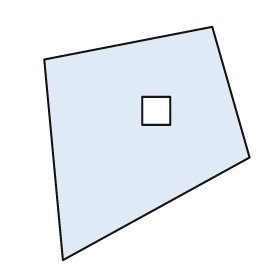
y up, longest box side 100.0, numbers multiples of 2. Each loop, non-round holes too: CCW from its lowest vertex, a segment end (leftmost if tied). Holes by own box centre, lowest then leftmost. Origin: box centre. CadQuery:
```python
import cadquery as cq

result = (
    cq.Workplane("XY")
    .moveTo(-36.0, -50.0)
    .lineTo(44.0, -6.0)
    .lineTo(28.0, 50.0)
    .lineTo(-44.0, 36.0)
    .close()
    .moveTo(-2.0, 8.0)
    .lineTo(10.0, 8.0)
    .lineTo(10.0, 20.0)
    .lineTo(-2.0, 20.0)
    .close()
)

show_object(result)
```